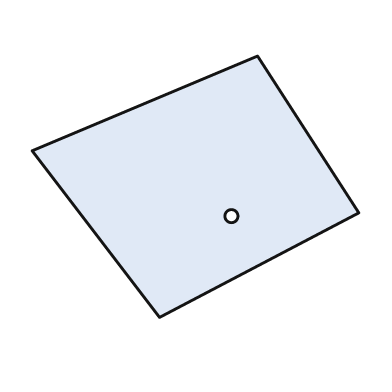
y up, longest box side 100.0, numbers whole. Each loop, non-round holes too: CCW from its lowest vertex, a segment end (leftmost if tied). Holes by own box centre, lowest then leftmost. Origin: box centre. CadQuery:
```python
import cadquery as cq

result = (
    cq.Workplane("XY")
    .moveTo(-11.0, -40.0)
    .lineTo(50.0, -8.0)
    .lineTo(19.0, 40.0)
    .lineTo(-50.0, 11.0)
    .close()
    .moveTo(11.0, -9.0)
    .circle(2.0)
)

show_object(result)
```